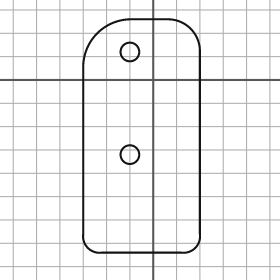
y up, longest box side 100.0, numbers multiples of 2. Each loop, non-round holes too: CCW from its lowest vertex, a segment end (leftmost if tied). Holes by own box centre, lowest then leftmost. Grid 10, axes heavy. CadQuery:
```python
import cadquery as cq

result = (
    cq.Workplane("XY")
    .moveTo(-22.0, -74.0)
    .lineTo(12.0, -74.0)
    .threePointArc((18.0, -72.0), (20.0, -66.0))
    .lineTo(20.0, 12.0)
    .threePointArc((16.0, 22.0), (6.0, 26.0))
    .lineTo(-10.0, 26.0)
    .threePointArc((-24.0, 20.0), (-30.0, 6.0))
    .lineTo(-30.0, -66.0)
    .threePointArc((-28.0, -72.0), (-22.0, -74.0))
    .close()
    .moveTo(-10.0, -32.0)
    .circle(4.0)
    .moveTo(-10.0, 12.0)
    .circle(4.0)
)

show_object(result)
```